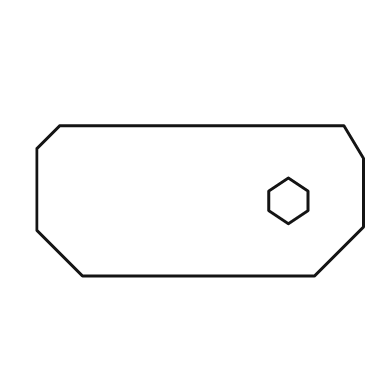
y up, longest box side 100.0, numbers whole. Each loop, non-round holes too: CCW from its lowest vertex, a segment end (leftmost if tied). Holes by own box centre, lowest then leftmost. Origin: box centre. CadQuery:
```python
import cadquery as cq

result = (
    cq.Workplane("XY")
    .moveTo(-36.0, -23.0)
    .lineTo(35.0, -23.0)
    .lineTo(50.0, -8.0)
    .lineTo(50.0, 13.0)
    .lineTo(44.0, 23.0)
    .lineTo(-43.0, 23.0)
    .lineTo(-50.0, 16.0)
    .lineTo(-50.0, -9.0)
    .close()
    .moveTo(27.0, -7.0)
    .lineTo(33.0, -3.0)
    .lineTo(33.0, 3.0)
    .lineTo(27.0, 7.0)
    .lineTo(21.0, 3.0)
    .lineTo(21.0, -3.0)
    .close()
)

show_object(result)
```